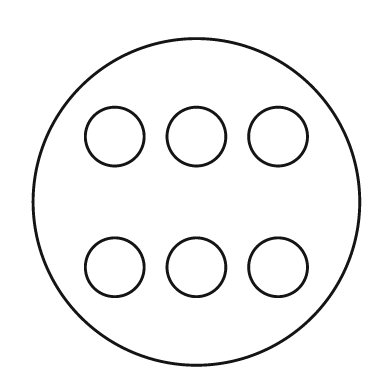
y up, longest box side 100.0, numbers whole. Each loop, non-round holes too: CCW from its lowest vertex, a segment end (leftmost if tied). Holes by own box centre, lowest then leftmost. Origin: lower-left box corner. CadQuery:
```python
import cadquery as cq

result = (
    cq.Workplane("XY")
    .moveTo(50.0, 50.0)
    .circle(50.0)
    .moveTo(25.0, 30.0)
    .circle(9.0)
    .moveTo(50.0, 30.0)
    .circle(9.0)
    .moveTo(75.0, 30.0)
    .circle(9.0)
    .moveTo(25.0, 70.0)
    .circle(9.0)
    .moveTo(50.0, 70.0)
    .circle(9.0)
    .moveTo(75.0, 70.0)
    .circle(9.0)
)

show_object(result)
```